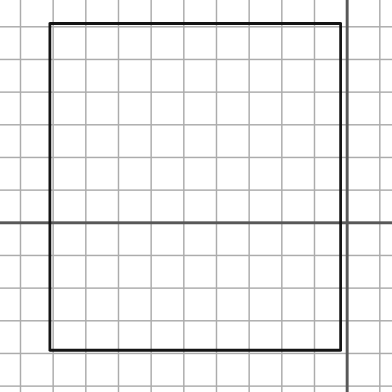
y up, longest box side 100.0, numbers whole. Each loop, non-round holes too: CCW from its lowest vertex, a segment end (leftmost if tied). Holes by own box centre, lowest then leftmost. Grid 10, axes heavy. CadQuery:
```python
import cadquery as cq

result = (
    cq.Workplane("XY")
    .moveTo(-91.0, -39.0)
    .lineTo(-2.0, -39.0)
    .lineTo(-2.0, 61.0)
    .lineTo(-91.0, 61.0)
    .close()
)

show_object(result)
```